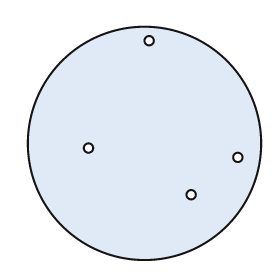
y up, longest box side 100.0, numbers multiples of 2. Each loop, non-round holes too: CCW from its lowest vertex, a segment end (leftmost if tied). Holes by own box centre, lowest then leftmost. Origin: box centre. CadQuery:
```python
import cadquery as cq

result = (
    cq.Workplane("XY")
    .moveTo(0.0, 0.0)
    .circle(50.0)
    .moveTo(20.0, -22.0)
    .circle(2.0)
    .moveTo(40.0, -6.0)
    .circle(2.0)
    .moveTo(-24.0, -2.0)
    .circle(2.0)
    .moveTo(2.0, 44.0)
    .circle(2.0)
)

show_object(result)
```